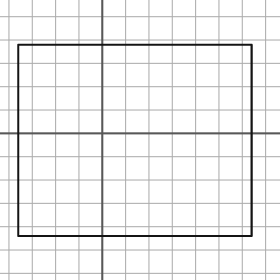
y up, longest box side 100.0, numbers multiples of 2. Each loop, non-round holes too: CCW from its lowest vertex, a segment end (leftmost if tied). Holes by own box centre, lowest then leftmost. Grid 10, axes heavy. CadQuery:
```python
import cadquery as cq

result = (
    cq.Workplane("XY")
    .moveTo(-36.0, -44.0)
    .lineTo(64.0, -44.0)
    .lineTo(64.0, 38.0)
    .lineTo(-36.0, 38.0)
    .close()
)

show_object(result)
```